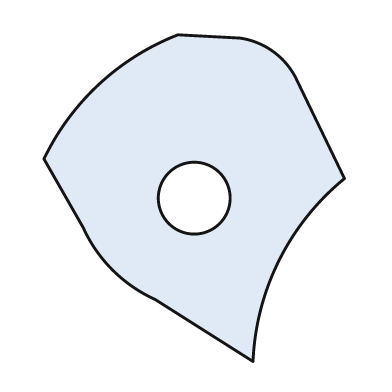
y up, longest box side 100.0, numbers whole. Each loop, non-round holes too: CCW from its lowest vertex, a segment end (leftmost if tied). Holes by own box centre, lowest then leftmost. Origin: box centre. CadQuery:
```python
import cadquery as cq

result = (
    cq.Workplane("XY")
    .moveTo(18.0, -50.0)
    .threePointArc((26.0, -19.0), (46.0, 6.0))
    .lineTo(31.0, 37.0)
    .threePointArc((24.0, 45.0), (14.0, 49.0))
    .lineTo(-5.0, 50.0)
    .threePointArc((-29.0, 35.0), (-46.0, 12.0))
    .lineTo(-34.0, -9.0)
    .threePointArc((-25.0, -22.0), (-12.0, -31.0))
    .close()
    .moveTo(0.0, 0.0)
    .circle(11.0)
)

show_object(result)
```